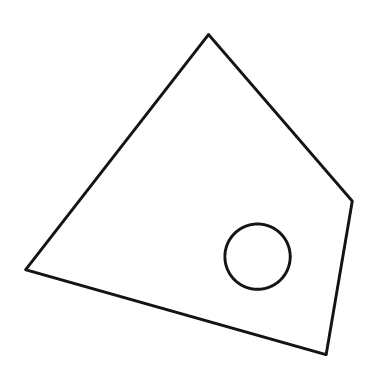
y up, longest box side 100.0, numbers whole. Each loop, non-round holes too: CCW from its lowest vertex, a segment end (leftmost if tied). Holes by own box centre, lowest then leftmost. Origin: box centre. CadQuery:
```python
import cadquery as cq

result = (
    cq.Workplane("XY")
    .moveTo(42.0, -49.0)
    .lineTo(50.0, -2.0)
    .lineTo(6.0, 49.0)
    .lineTo(-50.0, -23.0)
    .close()
    .moveTo(21.0, -19.0)
    .circle(10.0)
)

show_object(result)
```